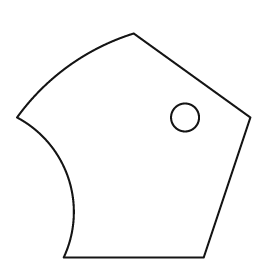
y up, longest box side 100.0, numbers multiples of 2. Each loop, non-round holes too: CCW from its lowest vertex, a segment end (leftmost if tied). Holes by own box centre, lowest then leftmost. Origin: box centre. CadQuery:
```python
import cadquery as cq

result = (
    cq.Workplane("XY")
    .moveTo(-30.0, -48.0)
    .lineTo(30.0, -48.0)
    .lineTo(50.0, 12.0)
    .lineTo(0.0, 48.0)
    .threePointArc((-28.0, 34.0), (-50.0, 12.0))
    .threePointArc((-28.0, -14.0), (-30.0, -48.0))
    .close()
    .moveTo(22.0, 12.0)
    .circle(6.0)
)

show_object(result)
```